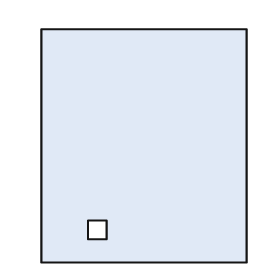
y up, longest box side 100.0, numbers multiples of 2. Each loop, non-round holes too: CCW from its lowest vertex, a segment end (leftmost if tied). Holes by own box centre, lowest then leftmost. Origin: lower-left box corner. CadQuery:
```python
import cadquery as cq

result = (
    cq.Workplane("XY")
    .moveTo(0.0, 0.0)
    .lineTo(88.0, 0.0)
    .lineTo(88.0, 100.0)
    .lineTo(0.0, 100.0)
    .close()
    .moveTo(20.0, 10.0)
    .lineTo(28.0, 10.0)
    .lineTo(28.0, 18.0)
    .lineTo(20.0, 18.0)
    .close()
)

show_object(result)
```